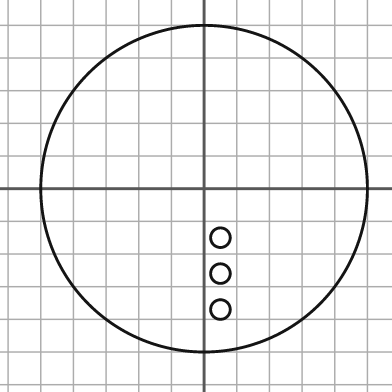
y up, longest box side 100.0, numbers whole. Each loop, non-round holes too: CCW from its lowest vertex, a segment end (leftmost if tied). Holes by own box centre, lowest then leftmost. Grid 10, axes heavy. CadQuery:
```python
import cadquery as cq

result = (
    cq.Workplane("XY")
    .moveTo(0.0, 0.0)
    .circle(50.0)
    .moveTo(5.0, -37.0)
    .circle(3.0)
    .moveTo(5.0, -26.0)
    .circle(3.0)
    .moveTo(5.0, -15.0)
    .circle(3.0)
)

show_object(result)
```